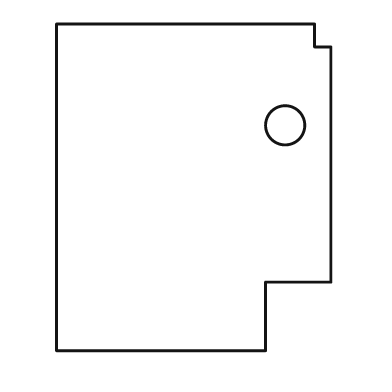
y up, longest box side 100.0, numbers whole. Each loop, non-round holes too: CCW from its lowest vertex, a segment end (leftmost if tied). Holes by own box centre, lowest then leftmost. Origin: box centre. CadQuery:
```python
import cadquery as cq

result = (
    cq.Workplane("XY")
    .moveTo(-42.0, -50.0)
    .lineTo(22.0, -50.0)
    .lineTo(22.0, -29.0)
    .lineTo(42.0, -29.0)
    .lineTo(42.0, 43.0)
    .lineTo(37.0, 43.0)
    .lineTo(37.0, 50.0)
    .lineTo(-42.0, 50.0)
    .close()
    .moveTo(28.0, 19.0)
    .circle(6.0)
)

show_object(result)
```